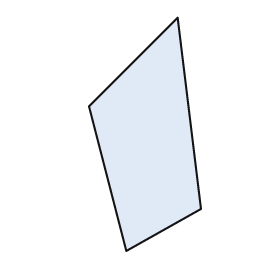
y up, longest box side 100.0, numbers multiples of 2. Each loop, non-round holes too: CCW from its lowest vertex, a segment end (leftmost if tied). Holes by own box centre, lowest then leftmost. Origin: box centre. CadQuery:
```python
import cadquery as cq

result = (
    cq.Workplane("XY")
    .moveTo(-8.0, -50.0)
    .lineTo(24.0, -32.0)
    .lineTo(14.0, 50.0)
    .lineTo(-24.0, 12.0)
    .close()
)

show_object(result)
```